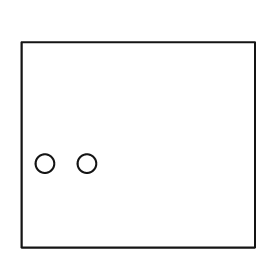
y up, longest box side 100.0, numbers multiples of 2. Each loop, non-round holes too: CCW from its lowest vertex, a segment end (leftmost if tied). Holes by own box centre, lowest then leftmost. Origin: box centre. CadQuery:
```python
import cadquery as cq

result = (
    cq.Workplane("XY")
    .moveTo(-50.0, -44.0)
    .lineTo(50.0, -44.0)
    .lineTo(50.0, 44.0)
    .lineTo(-50.0, 44.0)
    .close()
    .moveTo(-40.0, -8.0)
    .circle(4.0)
    .moveTo(-22.0, -8.0)
    .circle(4.0)
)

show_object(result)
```